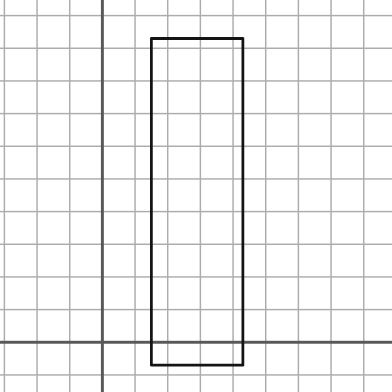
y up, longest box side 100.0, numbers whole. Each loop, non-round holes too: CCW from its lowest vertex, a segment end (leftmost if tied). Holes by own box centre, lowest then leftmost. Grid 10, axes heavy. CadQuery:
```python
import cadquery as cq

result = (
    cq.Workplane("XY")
    .moveTo(15.0, -7.0)
    .lineTo(43.0, -7.0)
    .lineTo(43.0, 93.0)
    .lineTo(15.0, 93.0)
    .close()
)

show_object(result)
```